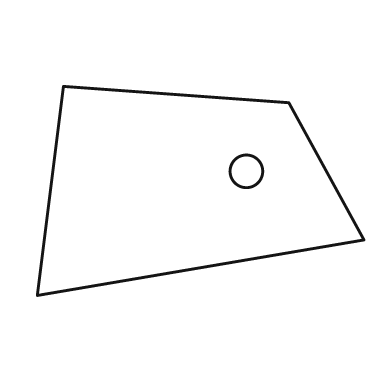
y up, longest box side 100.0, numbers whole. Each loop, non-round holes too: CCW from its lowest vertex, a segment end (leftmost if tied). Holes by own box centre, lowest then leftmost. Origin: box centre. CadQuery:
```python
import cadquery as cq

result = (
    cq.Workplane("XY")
    .moveTo(-50.0, -32.0)
    .lineTo(50.0, -15.0)
    .lineTo(27.0, 27.0)
    .lineTo(-42.0, 32.0)
    .close()
    .moveTo(14.0, 6.0)
    .circle(5.0)
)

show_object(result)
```